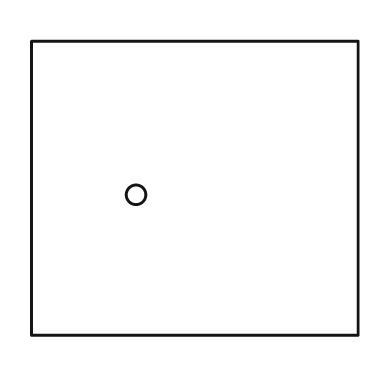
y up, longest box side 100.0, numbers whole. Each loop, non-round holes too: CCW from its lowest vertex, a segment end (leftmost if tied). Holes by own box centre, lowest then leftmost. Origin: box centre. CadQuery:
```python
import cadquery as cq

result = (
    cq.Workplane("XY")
    .moveTo(-50.0, -45.0)
    .lineTo(50.0, -45.0)
    .lineTo(50.0, 45.0)
    .lineTo(-50.0, 45.0)
    .close()
    .moveTo(-18.0, -2.0)
    .circle(3.0)
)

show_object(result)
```